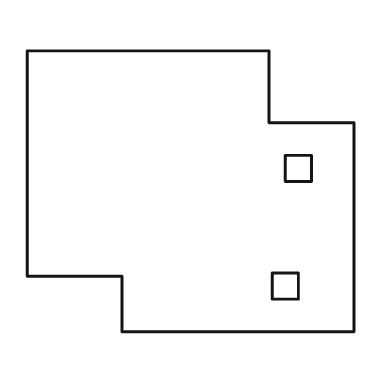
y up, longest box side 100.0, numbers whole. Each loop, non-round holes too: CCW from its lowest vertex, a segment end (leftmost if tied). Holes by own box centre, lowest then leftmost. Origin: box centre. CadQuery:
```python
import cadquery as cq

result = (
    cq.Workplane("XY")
    .moveTo(-21.0, -43.0)
    .lineTo(50.0, -43.0)
    .lineTo(50.0, 21.0)
    .lineTo(24.0, 21.0)
    .lineTo(24.0, 43.0)
    .lineTo(-50.0, 43.0)
    .lineTo(-50.0, -26.0)
    .lineTo(-21.0, -26.0)
    .close()
    .moveTo(25.0, -33.0)
    .lineTo(33.0, -33.0)
    .lineTo(33.0, -25.0)
    .lineTo(25.0, -25.0)
    .close()
    .moveTo(29.0, 3.0)
    .lineTo(37.0, 3.0)
    .lineTo(37.0, 11.0)
    .lineTo(29.0, 11.0)
    .close()
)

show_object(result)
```